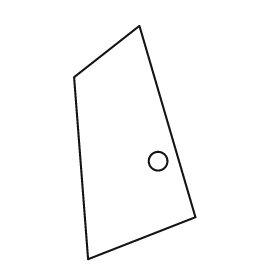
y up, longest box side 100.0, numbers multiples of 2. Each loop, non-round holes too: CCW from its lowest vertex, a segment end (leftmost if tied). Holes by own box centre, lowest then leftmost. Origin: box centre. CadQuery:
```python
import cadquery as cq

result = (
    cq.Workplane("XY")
    .moveTo(-20.0, -50.0)
    .lineTo(26.0, -32.0)
    .lineTo(2.0, 50.0)
    .lineTo(-26.0, 28.0)
    .close()
    .moveTo(10.0, -8.0)
    .circle(4.0)
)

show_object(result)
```